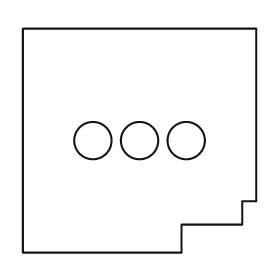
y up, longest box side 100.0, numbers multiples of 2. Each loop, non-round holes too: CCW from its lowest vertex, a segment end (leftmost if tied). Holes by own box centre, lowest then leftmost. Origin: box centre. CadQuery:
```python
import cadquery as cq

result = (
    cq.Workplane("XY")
    .moveTo(-50.0, -48.0)
    .lineTo(18.0, -48.0)
    .lineTo(18.0, -36.0)
    .lineTo(44.0, -36.0)
    .lineTo(44.0, -26.0)
    .lineTo(50.0, -26.0)
    .lineTo(50.0, 48.0)
    .lineTo(-50.0, 48.0)
    .close()
    .moveTo(-20.0, 0.0)
    .circle(8.0)
    .moveTo(0.0, 0.0)
    .circle(8.0)
    .moveTo(20.0, 0.0)
    .circle(8.0)
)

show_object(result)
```